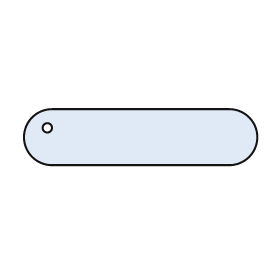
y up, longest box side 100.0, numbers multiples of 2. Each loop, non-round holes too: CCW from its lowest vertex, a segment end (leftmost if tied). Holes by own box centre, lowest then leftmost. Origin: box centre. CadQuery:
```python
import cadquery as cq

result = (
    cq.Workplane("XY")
    .moveTo(-38.0, -12.0)
    .lineTo(38.0, -12.0)
    .threePointArc((50.0, 0.0), (38.0, 12.0))
    .lineTo(-38.0, 12.0)
    .threePointArc((-50.0, 0.0), (-38.0, -12.0))
    .close()
    .moveTo(-40.0, 4.0)
    .circle(2.0)
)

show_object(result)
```